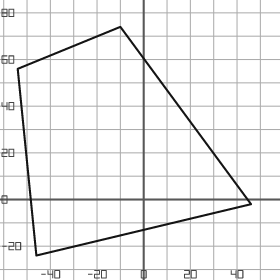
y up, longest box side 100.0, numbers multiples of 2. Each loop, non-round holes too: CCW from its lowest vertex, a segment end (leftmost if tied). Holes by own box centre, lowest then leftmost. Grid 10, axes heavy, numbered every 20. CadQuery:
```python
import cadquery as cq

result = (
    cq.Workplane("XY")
    .moveTo(-46.0, -24.0)
    .lineTo(46.0, -2.0)
    .lineTo(-10.0, 74.0)
    .lineTo(-54.0, 56.0)
    .close()
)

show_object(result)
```